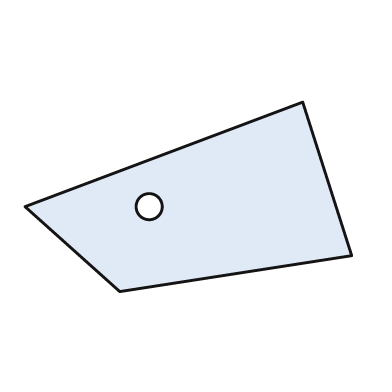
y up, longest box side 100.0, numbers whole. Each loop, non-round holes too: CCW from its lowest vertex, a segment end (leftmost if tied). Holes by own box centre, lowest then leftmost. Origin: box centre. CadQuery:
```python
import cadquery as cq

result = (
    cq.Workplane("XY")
    .moveTo(-21.0, -29.0)
    .lineTo(50.0, -18.0)
    .lineTo(35.0, 29.0)
    .lineTo(-50.0, -3.0)
    .close()
    .moveTo(-12.0, -3.0)
    .circle(4.0)
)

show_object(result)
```